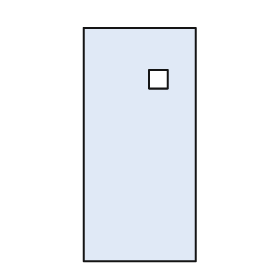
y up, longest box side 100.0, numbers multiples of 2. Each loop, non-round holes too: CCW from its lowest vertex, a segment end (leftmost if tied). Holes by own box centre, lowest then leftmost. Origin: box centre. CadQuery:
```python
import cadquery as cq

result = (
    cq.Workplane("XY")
    .moveTo(-24.0, -50.0)
    .lineTo(24.0, -50.0)
    .lineTo(24.0, 50.0)
    .lineTo(-24.0, 50.0)
    .close()
    .moveTo(4.0, 24.0)
    .lineTo(12.0, 24.0)
    .lineTo(12.0, 32.0)
    .lineTo(4.0, 32.0)
    .close()
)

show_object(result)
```